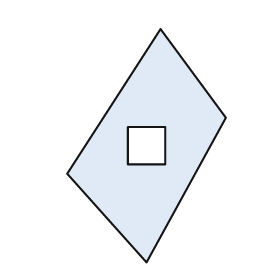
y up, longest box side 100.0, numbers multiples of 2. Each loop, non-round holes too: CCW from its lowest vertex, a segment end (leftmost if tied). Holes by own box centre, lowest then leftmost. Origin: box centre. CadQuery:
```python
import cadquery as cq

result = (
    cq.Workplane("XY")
    .moveTo(0.0, -50.0)
    .lineTo(34.0, 12.0)
    .lineTo(6.0, 50.0)
    .lineTo(-34.0, -12.0)
    .close()
    .moveTo(-8.0, -8.0)
    .lineTo(8.0, -8.0)
    .lineTo(8.0, 8.0)
    .lineTo(-8.0, 8.0)
    .close()
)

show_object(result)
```